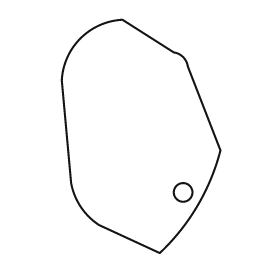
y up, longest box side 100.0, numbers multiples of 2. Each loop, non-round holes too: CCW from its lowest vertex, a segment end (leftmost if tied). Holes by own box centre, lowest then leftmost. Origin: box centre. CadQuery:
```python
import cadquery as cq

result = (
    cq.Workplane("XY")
    .moveTo(8.0, -50.0)
    .threePointArc((24.0, -30.0), (34.0, -6.0))
    .lineTo(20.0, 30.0)
    .threePointArc((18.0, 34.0), (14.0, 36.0))
    .lineTo(-8.0, 50.0)
    .threePointArc((-26.0, 42.0), (-34.0, 24.0))
    .lineTo(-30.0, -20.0)
    .threePointArc((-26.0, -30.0), (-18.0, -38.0))
    .close()
    .moveTo(18.0, -24.0)
    .circle(4.0)
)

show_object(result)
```